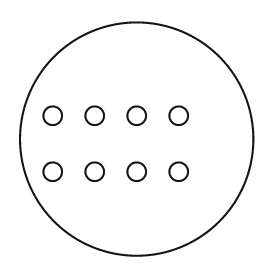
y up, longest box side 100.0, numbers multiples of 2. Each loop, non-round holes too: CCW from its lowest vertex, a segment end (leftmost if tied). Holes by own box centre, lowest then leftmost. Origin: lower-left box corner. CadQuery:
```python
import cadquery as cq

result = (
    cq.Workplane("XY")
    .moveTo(50.0, 50.0)
    .circle(50.0)
    .moveTo(14.0, 36.0)
    .circle(4.0)
    .moveTo(32.0, 36.0)
    .circle(4.0)
    .moveTo(50.0, 36.0)
    .circle(4.0)
    .moveTo(68.0, 36.0)
    .circle(4.0)
    .moveTo(14.0, 60.0)
    .circle(4.0)
    .moveTo(32.0, 60.0)
    .circle(4.0)
    .moveTo(50.0, 60.0)
    .circle(4.0)
    .moveTo(68.0, 60.0)
    .circle(4.0)
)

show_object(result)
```